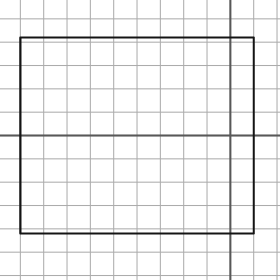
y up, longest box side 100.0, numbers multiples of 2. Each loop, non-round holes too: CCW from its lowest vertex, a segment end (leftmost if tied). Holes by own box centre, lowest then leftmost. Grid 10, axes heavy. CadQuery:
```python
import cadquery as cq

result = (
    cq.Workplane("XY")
    .moveTo(-90.0, -42.0)
    .lineTo(10.0, -42.0)
    .lineTo(10.0, 42.0)
    .lineTo(-90.0, 42.0)
    .close()
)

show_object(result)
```